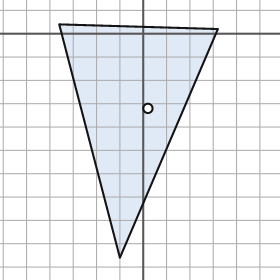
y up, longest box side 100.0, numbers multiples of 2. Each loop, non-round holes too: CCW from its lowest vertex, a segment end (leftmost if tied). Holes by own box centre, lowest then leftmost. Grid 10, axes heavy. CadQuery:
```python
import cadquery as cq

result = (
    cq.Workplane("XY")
    .moveTo(-10.0, -96.0)
    .lineTo(32.0, 2.0)
    .lineTo(-36.0, 4.0)
    .close()
    .moveTo(2.0, -32.0)
    .circle(2.0)
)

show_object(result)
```